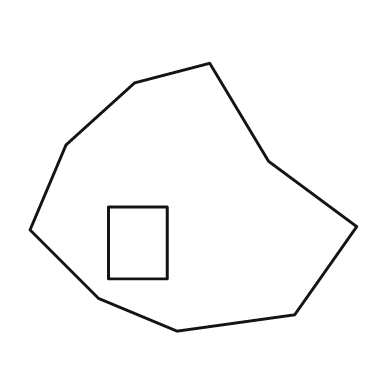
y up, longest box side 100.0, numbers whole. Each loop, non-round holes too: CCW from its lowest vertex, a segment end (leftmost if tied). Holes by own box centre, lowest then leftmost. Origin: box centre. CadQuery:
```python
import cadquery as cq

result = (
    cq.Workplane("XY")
    .moveTo(-5.0, -41.0)
    .lineTo(31.0, -36.0)
    .lineTo(50.0, -9.0)
    .lineTo(23.0, 11.0)
    .lineTo(5.0, 41.0)
    .lineTo(-18.0, 35.0)
    .lineTo(-39.0, 16.0)
    .lineTo(-50.0, -10.0)
    .lineTo(-29.0, -31.0)
    .close()
    .moveTo(-26.0, -25.0)
    .lineTo(-8.0, -25.0)
    .lineTo(-8.0, -3.0)
    .lineTo(-26.0, -3.0)
    .close()
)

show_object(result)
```